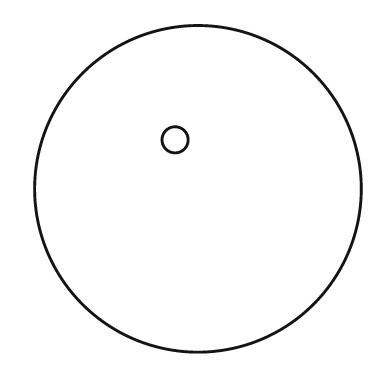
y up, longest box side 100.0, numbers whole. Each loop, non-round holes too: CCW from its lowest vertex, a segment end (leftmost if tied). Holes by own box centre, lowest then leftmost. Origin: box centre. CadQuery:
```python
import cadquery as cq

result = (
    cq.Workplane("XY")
    .moveTo(0.0, 0.0)
    .circle(50.0)
    .moveTo(-7.0, 15.0)
    .circle(4.0)
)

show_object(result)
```